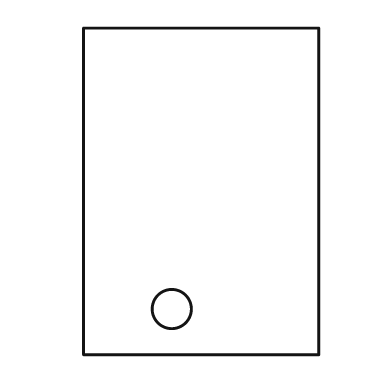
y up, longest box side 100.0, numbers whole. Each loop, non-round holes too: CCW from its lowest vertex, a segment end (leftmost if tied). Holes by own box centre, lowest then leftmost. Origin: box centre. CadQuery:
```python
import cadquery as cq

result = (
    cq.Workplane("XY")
    .moveTo(-36.0, -50.0)
    .lineTo(36.0, -50.0)
    .lineTo(36.0, 50.0)
    .lineTo(-36.0, 50.0)
    .close()
    .moveTo(-9.0, -36.0)
    .circle(6.0)
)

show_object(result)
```